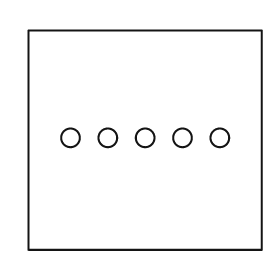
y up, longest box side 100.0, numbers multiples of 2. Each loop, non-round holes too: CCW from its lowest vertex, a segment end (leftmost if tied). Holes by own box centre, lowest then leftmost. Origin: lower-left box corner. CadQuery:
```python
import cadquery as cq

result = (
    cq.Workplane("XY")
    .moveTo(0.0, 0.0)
    .lineTo(100.0, 0.0)
    .lineTo(100.0, 94.0)
    .lineTo(0.0, 94.0)
    .close()
    .moveTo(18.0, 48.0)
    .circle(4.0)
    .moveTo(34.0, 48.0)
    .circle(4.0)
    .moveTo(50.0, 48.0)
    .circle(4.0)
    .moveTo(66.0, 48.0)
    .circle(4.0)
    .moveTo(82.0, 48.0)
    .circle(4.0)
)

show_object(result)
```